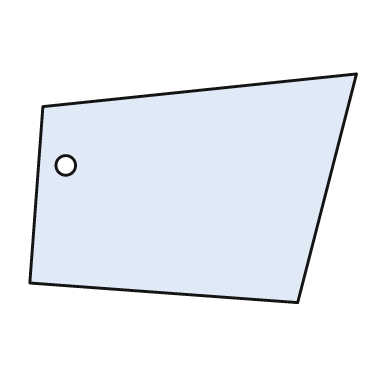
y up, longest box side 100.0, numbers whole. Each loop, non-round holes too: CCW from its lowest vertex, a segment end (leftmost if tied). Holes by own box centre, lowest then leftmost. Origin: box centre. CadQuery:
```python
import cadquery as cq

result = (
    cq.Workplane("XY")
    .moveTo(32.0, -35.0)
    .lineTo(50.0, 35.0)
    .lineTo(-46.0, 25.0)
    .lineTo(-50.0, -29.0)
    .close()
    .moveTo(-39.0, 7.0)
    .circle(3.0)
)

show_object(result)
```